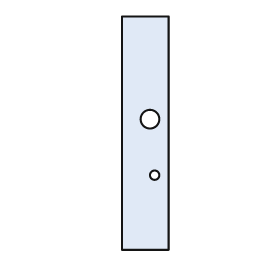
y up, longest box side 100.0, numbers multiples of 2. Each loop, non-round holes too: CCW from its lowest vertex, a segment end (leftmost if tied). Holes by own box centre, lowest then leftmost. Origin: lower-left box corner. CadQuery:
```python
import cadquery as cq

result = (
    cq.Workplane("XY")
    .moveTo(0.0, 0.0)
    .lineTo(20.0, 0.0)
    .lineTo(20.0, 100.0)
    .lineTo(0.0, 100.0)
    .close()
    .moveTo(14.0, 32.0)
    .circle(2.0)
    .moveTo(12.0, 56.0)
    .circle(4.0)
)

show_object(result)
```